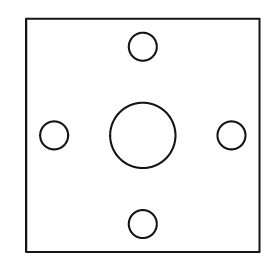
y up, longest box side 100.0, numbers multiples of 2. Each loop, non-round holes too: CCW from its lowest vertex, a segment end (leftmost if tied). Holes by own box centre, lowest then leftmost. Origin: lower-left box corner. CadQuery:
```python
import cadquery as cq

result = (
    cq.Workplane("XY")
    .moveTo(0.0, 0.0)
    .lineTo(100.0, 0.0)
    .lineTo(100.0, 100.0)
    .lineTo(0.0, 100.0)
    .close()
    .moveTo(50.0, 12.0)
    .circle(6.0)
    .moveTo(12.0, 50.0)
    .circle(6.0)
    .moveTo(50.0, 50.0)
    .circle(14.0)
    .moveTo(88.0, 50.0)
    .circle(6.0)
    .moveTo(50.0, 88.0)
    .circle(6.0)
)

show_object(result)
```